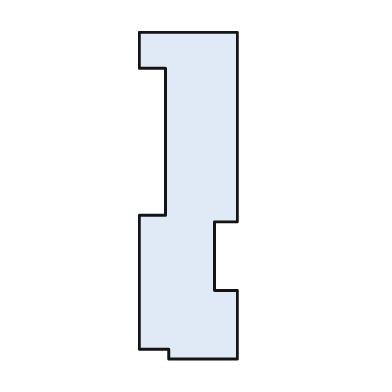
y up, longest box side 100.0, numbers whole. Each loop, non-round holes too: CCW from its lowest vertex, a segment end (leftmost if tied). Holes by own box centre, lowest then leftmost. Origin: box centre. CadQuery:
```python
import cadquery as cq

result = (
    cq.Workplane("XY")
    .moveTo(-6.0, -50.0)
    .lineTo(15.0, -50.0)
    .lineTo(15.0, -29.0)
    .lineTo(8.0, -29.0)
    .lineTo(8.0, -8.0)
    .lineTo(15.0, -8.0)
    .lineTo(15.0, 50.0)
    .lineTo(-15.0, 50.0)
    .lineTo(-15.0, 39.0)
    .lineTo(-7.0, 39.0)
    .lineTo(-7.0, -6.0)
    .lineTo(-15.0, -6.0)
    .lineTo(-15.0, -47.0)
    .lineTo(-6.0, -47.0)
    .close()
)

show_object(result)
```